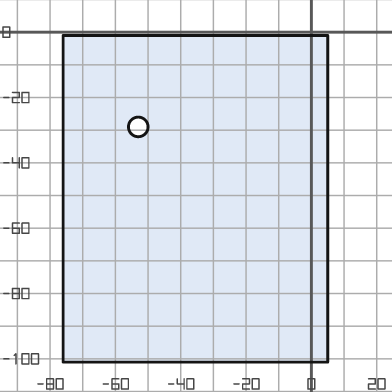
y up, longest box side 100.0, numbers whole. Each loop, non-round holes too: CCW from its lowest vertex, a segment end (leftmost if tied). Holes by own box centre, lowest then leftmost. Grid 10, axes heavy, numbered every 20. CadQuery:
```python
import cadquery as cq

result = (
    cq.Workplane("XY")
    .moveTo(-76.0, -101.0)
    .lineTo(5.0, -101.0)
    .lineTo(5.0, -1.0)
    .lineTo(-76.0, -1.0)
    .close()
    .moveTo(-53.0, -29.0)
    .circle(3.0)
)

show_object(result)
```